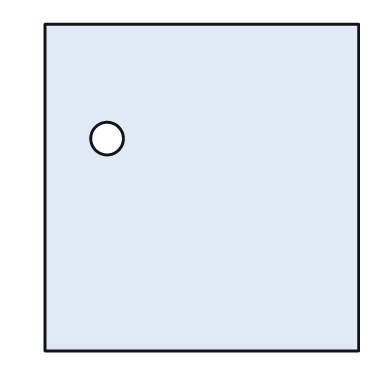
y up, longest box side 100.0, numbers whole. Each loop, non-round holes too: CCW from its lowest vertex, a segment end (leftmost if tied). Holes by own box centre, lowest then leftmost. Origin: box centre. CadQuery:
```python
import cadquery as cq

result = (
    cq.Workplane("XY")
    .moveTo(-48.0, -50.0)
    .lineTo(48.0, -50.0)
    .lineTo(48.0, 50.0)
    .lineTo(-48.0, 50.0)
    .close()
    .moveTo(-29.0, 15.0)
    .circle(5.0)
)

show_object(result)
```